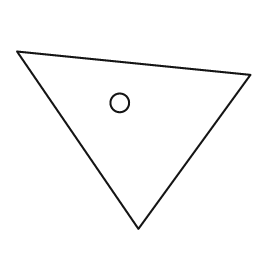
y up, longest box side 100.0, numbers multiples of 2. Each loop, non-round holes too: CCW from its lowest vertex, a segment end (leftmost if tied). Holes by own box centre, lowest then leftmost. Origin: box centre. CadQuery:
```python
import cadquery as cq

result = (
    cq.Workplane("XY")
    .moveTo(2.0, -38.0)
    .lineTo(50.0, 28.0)
    .lineTo(-50.0, 38.0)
    .close()
    .moveTo(-6.0, 16.0)
    .circle(4.0)
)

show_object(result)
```